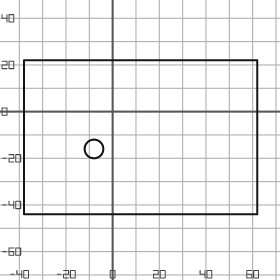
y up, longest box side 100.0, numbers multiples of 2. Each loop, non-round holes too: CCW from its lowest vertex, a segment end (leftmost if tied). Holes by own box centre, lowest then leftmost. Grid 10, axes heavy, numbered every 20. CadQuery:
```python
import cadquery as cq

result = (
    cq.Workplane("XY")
    .moveTo(-38.0, -44.0)
    .lineTo(62.0, -44.0)
    .lineTo(62.0, 22.0)
    .lineTo(-38.0, 22.0)
    .close()
    .moveTo(-8.0, -16.0)
    .circle(4.0)
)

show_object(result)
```